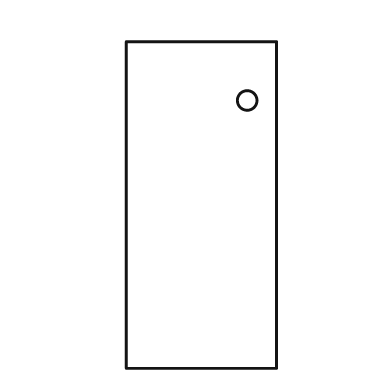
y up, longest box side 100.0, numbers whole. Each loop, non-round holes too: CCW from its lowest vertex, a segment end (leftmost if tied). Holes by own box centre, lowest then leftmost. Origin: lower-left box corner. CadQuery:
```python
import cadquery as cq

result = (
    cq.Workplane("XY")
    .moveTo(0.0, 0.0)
    .lineTo(46.0, 0.0)
    .lineTo(46.0, 100.0)
    .lineTo(0.0, 100.0)
    .close()
    .moveTo(37.0, 82.0)
    .circle(3.0)
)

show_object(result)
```